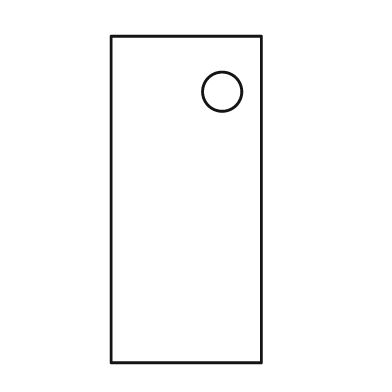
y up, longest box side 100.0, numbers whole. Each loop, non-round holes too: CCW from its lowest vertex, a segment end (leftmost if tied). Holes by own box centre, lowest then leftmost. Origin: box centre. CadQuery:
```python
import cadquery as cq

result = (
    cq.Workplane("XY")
    .moveTo(-23.0, -50.0)
    .lineTo(23.0, -50.0)
    .lineTo(23.0, 50.0)
    .lineTo(-23.0, 50.0)
    .close()
    .moveTo(11.0, 33.0)
    .circle(6.0)
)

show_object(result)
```